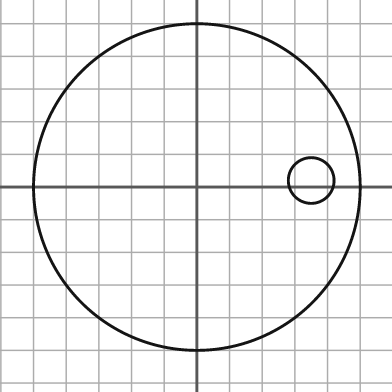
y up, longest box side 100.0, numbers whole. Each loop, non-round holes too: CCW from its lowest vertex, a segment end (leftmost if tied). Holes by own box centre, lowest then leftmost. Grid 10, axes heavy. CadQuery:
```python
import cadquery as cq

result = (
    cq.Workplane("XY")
    .moveTo(0.0, 0.0)
    .circle(50.0)
    .moveTo(35.0, 2.0)
    .circle(7.0)
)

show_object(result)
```